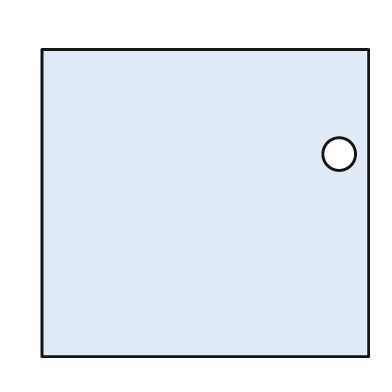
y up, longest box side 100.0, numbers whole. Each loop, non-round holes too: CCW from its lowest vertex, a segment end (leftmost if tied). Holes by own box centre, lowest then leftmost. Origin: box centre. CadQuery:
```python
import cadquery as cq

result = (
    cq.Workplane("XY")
    .moveTo(-50.0, -47.0)
    .lineTo(50.0, -47.0)
    .lineTo(50.0, 47.0)
    .lineTo(-50.0, 47.0)
    .close()
    .moveTo(41.0, 15.0)
    .circle(5.0)
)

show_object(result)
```